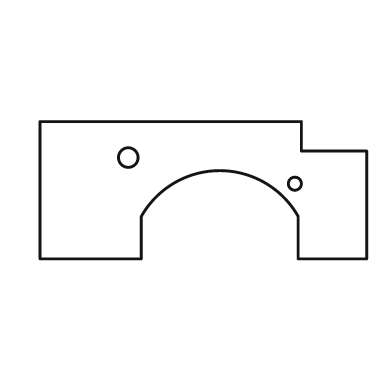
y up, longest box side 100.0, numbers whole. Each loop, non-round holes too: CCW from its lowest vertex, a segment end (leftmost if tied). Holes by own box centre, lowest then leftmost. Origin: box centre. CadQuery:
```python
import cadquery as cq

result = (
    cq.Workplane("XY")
    .moveTo(-50.0, -21.0)
    .lineTo(-19.0, -21.0)
    .lineTo(-19.0, -8.0)
    .threePointArc((5.0, 6.0), (29.0, -8.0))
    .lineTo(29.0, -21.0)
    .lineTo(50.0, -21.0)
    .lineTo(50.0, 12.0)
    .lineTo(30.0, 12.0)
    .lineTo(30.0, 21.0)
    .lineTo(-50.0, 21.0)
    .close()
    .moveTo(28.0, 2.0)
    .circle(2.0)
    .moveTo(-23.0, 10.0)
    .circle(3.0)
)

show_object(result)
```